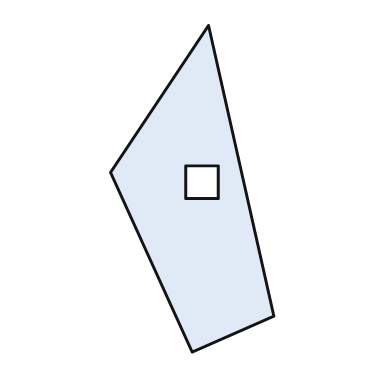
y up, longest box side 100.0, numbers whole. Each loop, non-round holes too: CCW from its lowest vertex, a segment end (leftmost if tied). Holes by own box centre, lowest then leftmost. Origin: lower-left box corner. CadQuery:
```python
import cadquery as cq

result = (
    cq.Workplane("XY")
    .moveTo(25.0, 0.0)
    .lineTo(50.0, 11.0)
    .lineTo(30.0, 100.0)
    .lineTo(0.0, 55.0)
    .close()
    .moveTo(23.0, 47.0)
    .lineTo(33.0, 47.0)
    .lineTo(33.0, 57.0)
    .lineTo(23.0, 57.0)
    .close()
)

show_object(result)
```